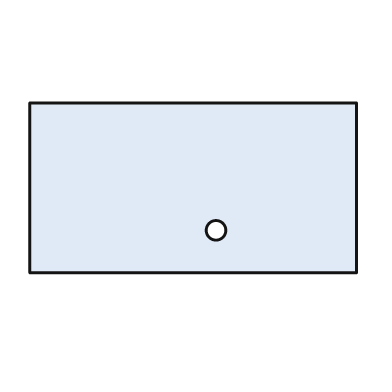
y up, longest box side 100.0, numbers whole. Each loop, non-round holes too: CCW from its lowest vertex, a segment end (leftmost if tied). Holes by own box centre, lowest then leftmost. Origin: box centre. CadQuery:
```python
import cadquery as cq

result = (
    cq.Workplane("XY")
    .moveTo(-50.0, -26.0)
    .lineTo(50.0, -26.0)
    .lineTo(50.0, 26.0)
    .lineTo(-50.0, 26.0)
    .close()
    .moveTo(7.0, -13.0)
    .circle(3.0)
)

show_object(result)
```